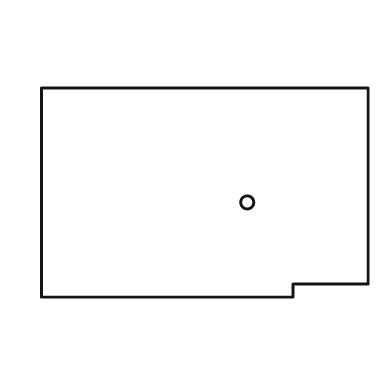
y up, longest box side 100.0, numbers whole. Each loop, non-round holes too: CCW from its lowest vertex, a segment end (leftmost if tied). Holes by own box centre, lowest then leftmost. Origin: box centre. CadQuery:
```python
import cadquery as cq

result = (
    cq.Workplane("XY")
    .moveTo(-50.0, -32.0)
    .lineTo(27.0, -32.0)
    .lineTo(27.0, -28.0)
    .lineTo(50.0, -28.0)
    .lineTo(50.0, 32.0)
    .lineTo(-50.0, 32.0)
    .close()
    .moveTo(13.0, -3.0)
    .circle(2.0)
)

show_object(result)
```